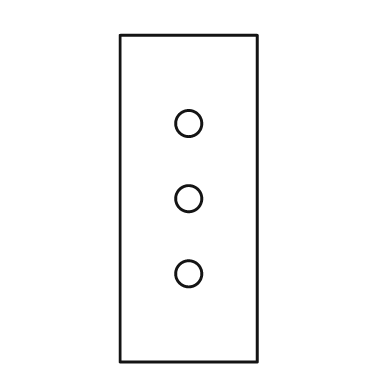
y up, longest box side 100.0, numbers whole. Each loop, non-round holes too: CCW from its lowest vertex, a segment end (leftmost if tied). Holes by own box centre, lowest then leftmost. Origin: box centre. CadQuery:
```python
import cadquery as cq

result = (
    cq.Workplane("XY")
    .moveTo(-21.0, -50.0)
    .lineTo(21.0, -50.0)
    .lineTo(21.0, 50.0)
    .lineTo(-21.0, 50.0)
    .close()
    .moveTo(0.0, -23.0)
    .circle(4.0)
    .moveTo(0.0, 0.0)
    .circle(4.0)
    .moveTo(0.0, 23.0)
    .circle(4.0)
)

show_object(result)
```